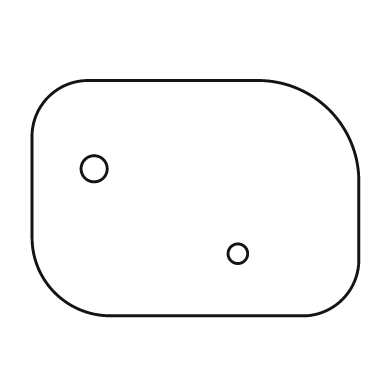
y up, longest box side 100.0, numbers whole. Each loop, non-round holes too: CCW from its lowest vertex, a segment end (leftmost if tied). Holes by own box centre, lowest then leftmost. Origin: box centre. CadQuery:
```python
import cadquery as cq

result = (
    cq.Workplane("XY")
    .moveTo(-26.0, -36.0)
    .lineTo(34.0, -36.0)
    .threePointArc((45.0, -31.0), (50.0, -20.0))
    .lineTo(50.0, 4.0)
    .threePointArc((41.0, 27.0), (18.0, 36.0))
    .lineTo(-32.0, 36.0)
    .threePointArc((-45.0, 31.0), (-50.0, 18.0))
    .lineTo(-50.0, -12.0)
    .threePointArc((-43.0, -29.0), (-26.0, -36.0))
    .close()
    .moveTo(13.0, -17.0)
    .circle(3.0)
    .moveTo(-31.0, 9.0)
    .circle(4.0)
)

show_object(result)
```